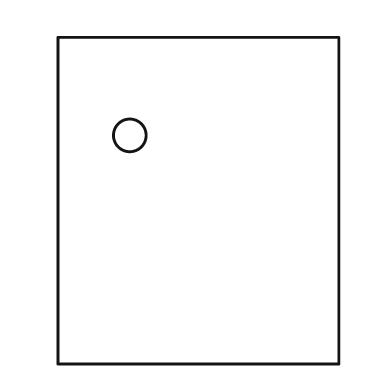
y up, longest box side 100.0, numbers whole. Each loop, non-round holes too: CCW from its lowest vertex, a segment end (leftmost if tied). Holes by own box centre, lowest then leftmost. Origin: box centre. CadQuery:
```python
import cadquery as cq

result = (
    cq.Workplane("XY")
    .moveTo(-43.0, -50.0)
    .lineTo(43.0, -50.0)
    .lineTo(43.0, 50.0)
    .lineTo(-43.0, 50.0)
    .close()
    .moveTo(-21.0, 20.0)
    .circle(5.0)
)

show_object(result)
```